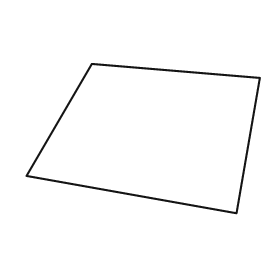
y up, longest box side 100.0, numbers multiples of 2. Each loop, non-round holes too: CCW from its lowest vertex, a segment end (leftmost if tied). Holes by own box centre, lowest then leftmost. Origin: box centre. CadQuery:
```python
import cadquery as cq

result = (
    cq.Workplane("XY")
    .moveTo(40.0, -32.0)
    .lineTo(50.0, 26.0)
    .lineTo(-22.0, 32.0)
    .lineTo(-50.0, -16.0)
    .close()
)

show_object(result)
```